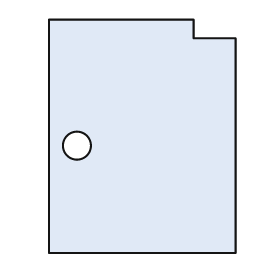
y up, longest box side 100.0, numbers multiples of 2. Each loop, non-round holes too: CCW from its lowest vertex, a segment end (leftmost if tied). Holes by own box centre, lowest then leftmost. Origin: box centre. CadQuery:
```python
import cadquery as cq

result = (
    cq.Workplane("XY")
    .moveTo(-40.0, -50.0)
    .lineTo(40.0, -50.0)
    .lineTo(40.0, 42.0)
    .lineTo(22.0, 42.0)
    .lineTo(22.0, 50.0)
    .lineTo(-40.0, 50.0)
    .close()
    .moveTo(-28.0, -4.0)
    .circle(6.0)
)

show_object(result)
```